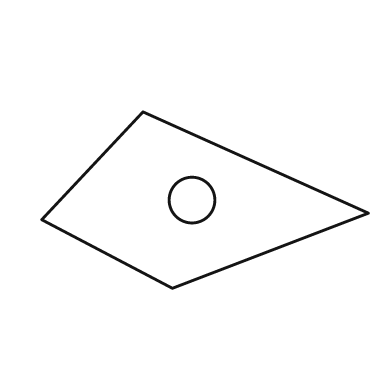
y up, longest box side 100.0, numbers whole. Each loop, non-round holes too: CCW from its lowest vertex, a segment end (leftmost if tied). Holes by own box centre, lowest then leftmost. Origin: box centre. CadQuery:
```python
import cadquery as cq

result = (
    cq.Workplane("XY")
    .moveTo(-10.0, -27.0)
    .lineTo(50.0, -4.0)
    .lineTo(-19.0, 27.0)
    .lineTo(-50.0, -6.0)
    .close()
    .moveTo(-4.0, 0.0)
    .circle(7.0)
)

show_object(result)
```